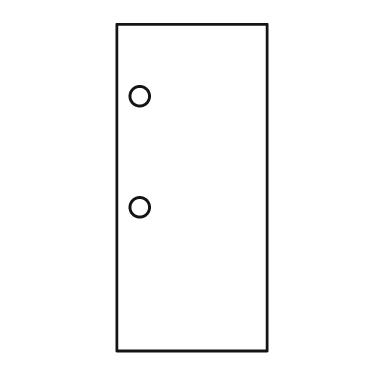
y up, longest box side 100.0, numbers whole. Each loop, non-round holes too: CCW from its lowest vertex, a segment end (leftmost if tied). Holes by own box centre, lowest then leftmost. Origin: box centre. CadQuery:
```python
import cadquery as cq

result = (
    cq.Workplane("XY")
    .moveTo(-23.0, -50.0)
    .lineTo(23.0, -50.0)
    .lineTo(23.0, 50.0)
    .lineTo(-23.0, 50.0)
    .close()
    .moveTo(-16.0, -6.0)
    .circle(3.0)
    .moveTo(-16.0, 28.0)
    .circle(3.0)
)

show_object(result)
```